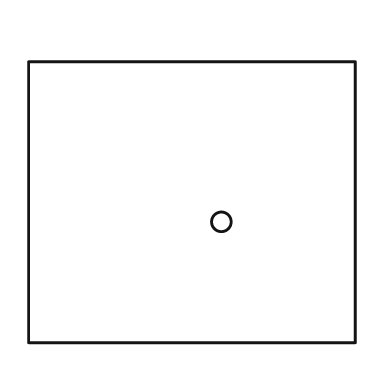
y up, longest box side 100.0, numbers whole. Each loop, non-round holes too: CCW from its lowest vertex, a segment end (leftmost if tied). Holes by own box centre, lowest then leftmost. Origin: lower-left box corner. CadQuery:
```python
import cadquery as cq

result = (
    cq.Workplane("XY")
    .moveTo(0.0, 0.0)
    .lineTo(100.0, 0.0)
    .lineTo(100.0, 86.0)
    .lineTo(0.0, 86.0)
    .close()
    .moveTo(59.0, 37.0)
    .circle(3.0)
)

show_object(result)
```